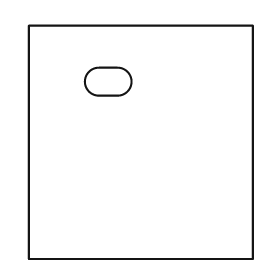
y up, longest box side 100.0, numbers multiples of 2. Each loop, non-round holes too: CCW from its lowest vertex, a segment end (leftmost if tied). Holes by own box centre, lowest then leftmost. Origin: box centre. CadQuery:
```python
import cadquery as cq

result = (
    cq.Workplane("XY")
    .moveTo(-48.0, -50.0)
    .lineTo(48.0, -50.0)
    .lineTo(48.0, 50.0)
    .lineTo(-48.0, 50.0)
    .close()
    .moveTo(-18.0, 20.0)
    .lineTo(-10.0, 20.0)
    .threePointArc((-4.0, 26.0), (-10.0, 32.0))
    .lineTo(-18.0, 32.0)
    .threePointArc((-24.0, 26.0), (-18.0, 20.0))
    .close()
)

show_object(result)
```